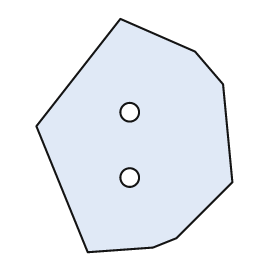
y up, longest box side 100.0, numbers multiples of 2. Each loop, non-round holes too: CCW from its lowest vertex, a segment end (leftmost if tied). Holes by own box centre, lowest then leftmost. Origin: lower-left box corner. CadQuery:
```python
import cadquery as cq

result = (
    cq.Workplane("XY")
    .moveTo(22.0, 0.0)
    .lineTo(50.0, 2.0)
    .lineTo(60.0, 6.0)
    .lineTo(84.0, 30.0)
    .lineTo(80.0, 72.0)
    .lineTo(68.0, 86.0)
    .lineTo(36.0, 100.0)
    .lineTo(0.0, 54.0)
    .close()
    .moveTo(40.0, 32.0)
    .circle(4.0)
    .moveTo(40.0, 60.0)
    .circle(4.0)
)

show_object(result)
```